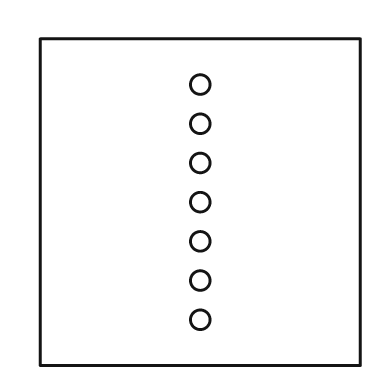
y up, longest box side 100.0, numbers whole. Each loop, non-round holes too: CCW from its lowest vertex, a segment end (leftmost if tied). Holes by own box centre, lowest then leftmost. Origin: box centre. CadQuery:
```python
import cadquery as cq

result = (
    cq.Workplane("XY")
    .moveTo(-49.0, -50.0)
    .lineTo(49.0, -50.0)
    .lineTo(49.0, 50.0)
    .lineTo(-49.0, 50.0)
    .close()
    .moveTo(0.0, -36.0)
    .circle(3.0)
    .moveTo(0.0, -24.0)
    .circle(3.0)
    .moveTo(0.0, -12.0)
    .circle(3.0)
    .moveTo(0.0, 0.0)
    .circle(3.0)
    .moveTo(0.0, 12.0)
    .circle(3.0)
    .moveTo(0.0, 24.0)
    .circle(3.0)
    .moveTo(0.0, 36.0)
    .circle(3.0)
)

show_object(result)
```